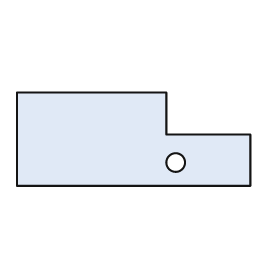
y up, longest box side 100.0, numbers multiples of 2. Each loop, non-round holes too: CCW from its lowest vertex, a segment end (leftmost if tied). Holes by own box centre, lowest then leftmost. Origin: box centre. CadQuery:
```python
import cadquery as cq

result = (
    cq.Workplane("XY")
    .moveTo(-50.0, -20.0)
    .lineTo(50.0, -20.0)
    .lineTo(50.0, 2.0)
    .lineTo(14.0, 2.0)
    .lineTo(14.0, 20.0)
    .lineTo(-50.0, 20.0)
    .close()
    .moveTo(18.0, -10.0)
    .circle(4.0)
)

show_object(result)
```